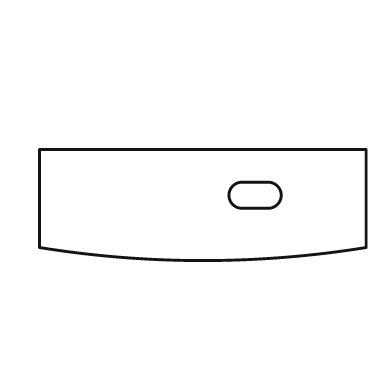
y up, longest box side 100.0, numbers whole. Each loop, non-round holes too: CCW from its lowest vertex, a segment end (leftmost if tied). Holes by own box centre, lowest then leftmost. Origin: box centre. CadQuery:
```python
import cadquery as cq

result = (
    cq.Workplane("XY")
    .moveTo(-50.0, -13.0)
    .threePointArc((0.0, -17.0), (50.0, -13.0))
    .lineTo(50.0, 17.0)
    .lineTo(-50.0, 17.0)
    .close()
    .moveTo(12.0, -1.0)
    .lineTo(20.0, -1.0)
    .threePointArc((24.0, 3.0), (20.0, 7.0))
    .lineTo(12.0, 7.0)
    .threePointArc((8.0, 3.0), (12.0, -1.0))
    .close()
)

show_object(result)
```